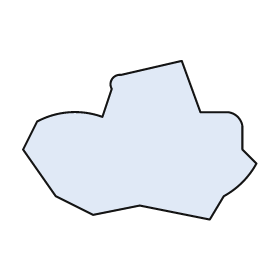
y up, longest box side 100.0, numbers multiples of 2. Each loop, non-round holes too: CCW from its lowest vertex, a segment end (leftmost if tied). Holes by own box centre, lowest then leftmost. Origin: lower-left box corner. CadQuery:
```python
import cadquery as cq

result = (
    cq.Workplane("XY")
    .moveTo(80.0, 0.0)
    .lineTo(86.0, 10.0)
    .threePointArc((94.0, 16.0), (100.0, 24.0))
    .lineTo(94.0, 30.0)
    .lineTo(94.0, 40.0)
    .threePointArc((92.0, 44.0), (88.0, 46.0))
    .lineTo(76.0, 46.0)
    .lineTo(68.0, 68.0)
    .lineTo(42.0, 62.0)
    .threePointArc((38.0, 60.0), (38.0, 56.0))
    .lineTo(34.0, 44.0)
    .threePointArc((20.0, 46.0), (6.0, 42.0))
    .lineTo(0.0, 30.0)
    .lineTo(14.0, 10.0)
    .lineTo(30.0, 2.0)
    .lineTo(50.0, 6.0)
    .close()
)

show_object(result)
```